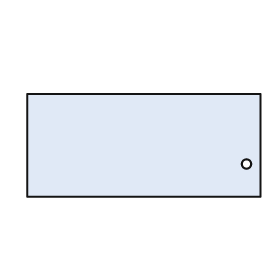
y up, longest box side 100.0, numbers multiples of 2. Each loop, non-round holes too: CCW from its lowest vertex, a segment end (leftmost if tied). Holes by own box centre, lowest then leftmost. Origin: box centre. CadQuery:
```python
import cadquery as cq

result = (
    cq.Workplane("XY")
    .moveTo(-50.0, -22.0)
    .lineTo(50.0, -22.0)
    .lineTo(50.0, 22.0)
    .lineTo(-50.0, 22.0)
    .close()
    .moveTo(44.0, -8.0)
    .circle(2.0)
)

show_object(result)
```